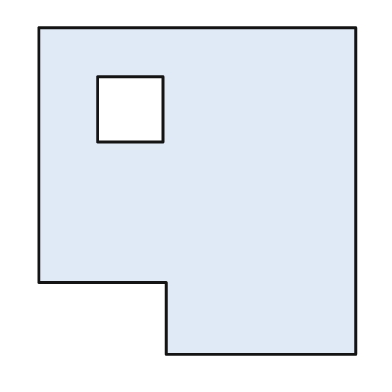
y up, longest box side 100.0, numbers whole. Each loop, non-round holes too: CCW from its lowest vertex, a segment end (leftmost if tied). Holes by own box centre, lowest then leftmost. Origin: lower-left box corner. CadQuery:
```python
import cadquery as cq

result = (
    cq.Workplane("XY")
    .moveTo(39.0, 0.0)
    .lineTo(97.0, 0.0)
    .lineTo(97.0, 100.0)
    .lineTo(0.0, 100.0)
    .lineTo(0.0, 22.0)
    .lineTo(39.0, 22.0)
    .close()
    .moveTo(18.0, 65.0)
    .lineTo(38.0, 65.0)
    .lineTo(38.0, 85.0)
    .lineTo(18.0, 85.0)
    .close()
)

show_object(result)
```